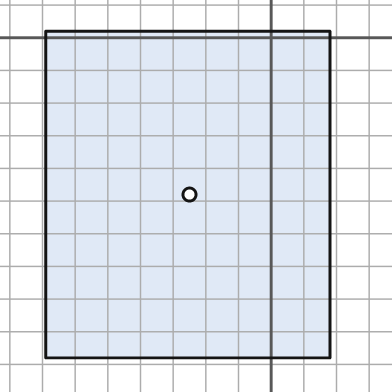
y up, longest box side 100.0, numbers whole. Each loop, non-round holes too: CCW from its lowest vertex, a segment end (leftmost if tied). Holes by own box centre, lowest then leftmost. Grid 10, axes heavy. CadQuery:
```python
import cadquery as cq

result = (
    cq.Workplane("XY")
    .moveTo(-69.0, -98.0)
    .lineTo(18.0, -98.0)
    .lineTo(18.0, 2.0)
    .lineTo(-69.0, 2.0)
    .close()
    .moveTo(-25.0, -48.0)
    .circle(2.0)
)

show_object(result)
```